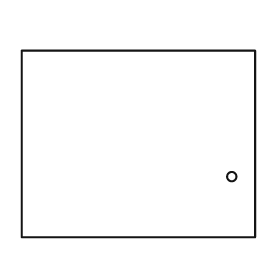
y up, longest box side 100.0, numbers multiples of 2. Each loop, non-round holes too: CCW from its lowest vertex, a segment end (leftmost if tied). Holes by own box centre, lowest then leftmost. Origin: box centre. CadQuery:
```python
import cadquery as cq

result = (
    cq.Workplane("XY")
    .moveTo(-50.0, -40.0)
    .lineTo(50.0, -40.0)
    .lineTo(50.0, 40.0)
    .lineTo(-50.0, 40.0)
    .close()
    .moveTo(40.0, -14.0)
    .circle(2.0)
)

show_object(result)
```